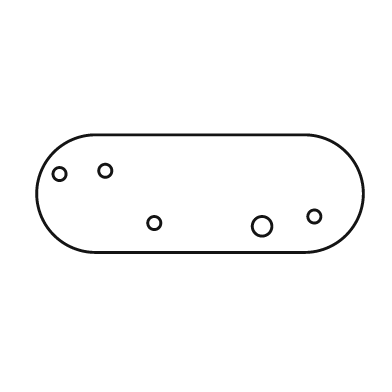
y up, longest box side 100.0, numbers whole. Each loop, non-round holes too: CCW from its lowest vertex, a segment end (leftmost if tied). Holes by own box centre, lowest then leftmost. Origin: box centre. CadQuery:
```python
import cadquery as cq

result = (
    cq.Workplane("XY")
    .moveTo(-32.0, -18.0)
    .lineTo(32.0, -18.0)
    .threePointArc((50.0, 0.0), (32.0, 18.0))
    .lineTo(-32.0, 18.0)
    .threePointArc((-50.0, 0.0), (-32.0, -18.0))
    .close()
    .moveTo(19.0, -10.0)
    .circle(3.0)
    .moveTo(-14.0, -9.0)
    .circle(2.0)
    .moveTo(35.0, -7.0)
    .circle(2.0)
    .moveTo(-43.0, 6.0)
    .circle(2.0)
    .moveTo(-29.0, 7.0)
    .circle(2.0)
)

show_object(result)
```